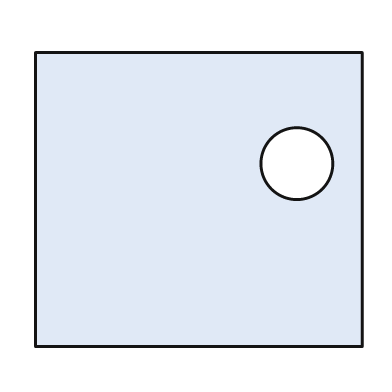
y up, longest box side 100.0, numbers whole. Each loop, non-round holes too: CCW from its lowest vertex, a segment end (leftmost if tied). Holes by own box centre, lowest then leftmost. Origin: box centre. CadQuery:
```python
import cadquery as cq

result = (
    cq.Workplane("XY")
    .moveTo(-50.0, -45.0)
    .lineTo(50.0, -45.0)
    .lineTo(50.0, 45.0)
    .lineTo(-50.0, 45.0)
    .close()
    .moveTo(30.0, 11.0)
    .circle(11.0)
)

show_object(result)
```